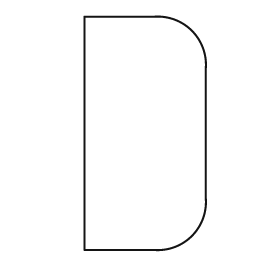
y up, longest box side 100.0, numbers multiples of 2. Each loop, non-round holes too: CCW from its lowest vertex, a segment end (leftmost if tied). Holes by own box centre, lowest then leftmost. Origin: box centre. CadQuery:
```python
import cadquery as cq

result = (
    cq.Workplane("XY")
    .moveTo(-26.0, -50.0)
    .lineTo(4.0, -50.0)
    .threePointArc((20.0, -44.0), (26.0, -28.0))
    .lineTo(26.0, 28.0)
    .threePointArc((20.0, 44.0), (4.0, 50.0))
    .lineTo(-26.0, 50.0)
    .close()
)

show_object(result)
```